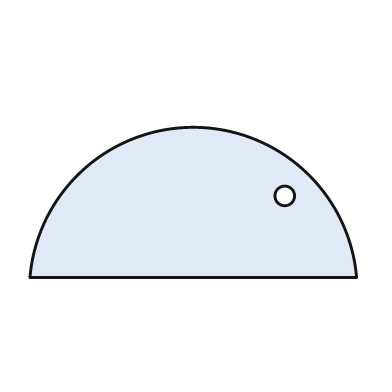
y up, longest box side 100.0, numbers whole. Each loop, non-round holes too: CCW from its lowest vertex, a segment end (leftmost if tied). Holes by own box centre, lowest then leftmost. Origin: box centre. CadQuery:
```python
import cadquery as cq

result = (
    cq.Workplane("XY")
    .moveTo(-50.0, -23.0)
    .lineTo(50.0, -23.0)
    .threePointArc((0.0, 23.0), (-50.0, -23.0))
    .close()
    .moveTo(28.0, 2.0)
    .circle(3.0)
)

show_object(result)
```